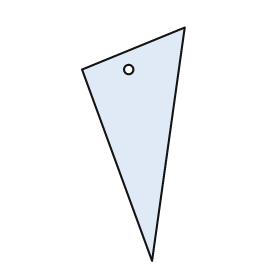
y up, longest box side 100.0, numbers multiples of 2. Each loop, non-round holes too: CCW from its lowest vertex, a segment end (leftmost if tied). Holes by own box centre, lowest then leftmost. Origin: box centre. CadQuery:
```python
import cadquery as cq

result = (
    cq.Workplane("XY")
    .moveTo(8.0, -50.0)
    .lineTo(22.0, 50.0)
    .lineTo(-22.0, 32.0)
    .close()
    .moveTo(-2.0, 32.0)
    .circle(2.0)
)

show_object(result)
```